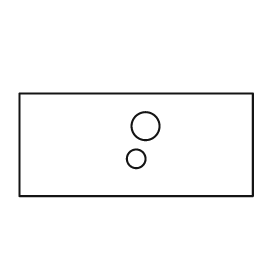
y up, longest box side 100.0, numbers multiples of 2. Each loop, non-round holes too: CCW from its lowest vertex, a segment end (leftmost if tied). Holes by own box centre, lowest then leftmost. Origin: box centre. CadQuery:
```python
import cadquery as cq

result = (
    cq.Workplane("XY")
    .moveTo(-50.0, -22.0)
    .lineTo(50.0, -22.0)
    .lineTo(50.0, 22.0)
    .lineTo(-50.0, 22.0)
    .close()
    .moveTo(0.0, -6.0)
    .circle(4.0)
    .moveTo(4.0, 8.0)
    .circle(6.0)
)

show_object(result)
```